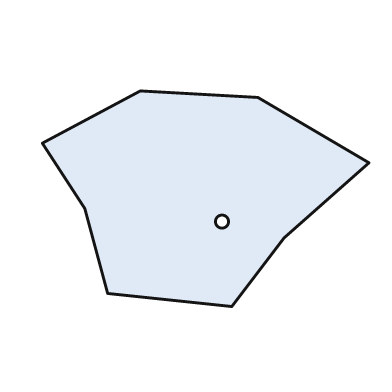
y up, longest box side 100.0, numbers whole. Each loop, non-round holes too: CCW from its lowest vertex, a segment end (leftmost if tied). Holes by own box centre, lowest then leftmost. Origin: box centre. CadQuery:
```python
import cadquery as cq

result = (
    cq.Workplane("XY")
    .moveTo(8.0, -33.0)
    .lineTo(24.0, -12.0)
    .lineTo(50.0, 11.0)
    .lineTo(16.0, 31.0)
    .lineTo(-20.0, 33.0)
    .lineTo(-50.0, 17.0)
    .lineTo(-37.0, -3.0)
    .lineTo(-30.0, -29.0)
    .close()
    .moveTo(5.0, -7.0)
    .circle(2.0)
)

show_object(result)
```